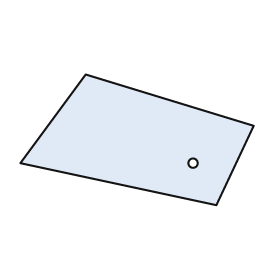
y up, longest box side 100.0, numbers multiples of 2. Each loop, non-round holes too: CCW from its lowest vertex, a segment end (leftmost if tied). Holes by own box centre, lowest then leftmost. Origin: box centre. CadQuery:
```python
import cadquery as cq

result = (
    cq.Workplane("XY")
    .moveTo(34.0, -28.0)
    .lineTo(50.0, 6.0)
    .lineTo(-22.0, 28.0)
    .lineTo(-50.0, -10.0)
    .close()
    .moveTo(24.0, -10.0)
    .circle(2.0)
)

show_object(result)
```